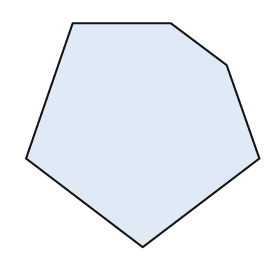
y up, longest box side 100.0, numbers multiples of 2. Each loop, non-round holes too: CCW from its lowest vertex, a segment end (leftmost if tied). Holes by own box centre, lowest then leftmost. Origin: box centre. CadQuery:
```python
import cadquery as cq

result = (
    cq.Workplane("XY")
    .moveTo(0.0, -48.0)
    .lineTo(50.0, -10.0)
    .lineTo(36.0, 30.0)
    .lineTo(12.0, 48.0)
    .lineTo(-30.0, 48.0)
    .lineTo(-50.0, -10.0)
    .close()
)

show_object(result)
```